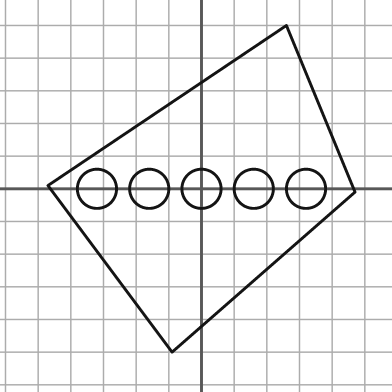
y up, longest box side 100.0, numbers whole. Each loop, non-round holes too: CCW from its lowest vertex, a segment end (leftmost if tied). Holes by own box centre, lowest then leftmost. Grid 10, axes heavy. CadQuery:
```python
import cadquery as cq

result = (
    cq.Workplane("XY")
    .moveTo(-9.0, -50.0)
    .lineTo(47.0, -1.0)
    .lineTo(26.0, 50.0)
    .lineTo(-47.0, 1.0)
    .close()
    .moveTo(-32.0, 0.0)
    .circle(6.0)
    .moveTo(-16.0, 0.0)
    .circle(6.0)
    .moveTo(0.0, 0.0)
    .circle(6.0)
    .moveTo(16.0, 0.0)
    .circle(6.0)
    .moveTo(32.0, 0.0)
    .circle(6.0)
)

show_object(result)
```